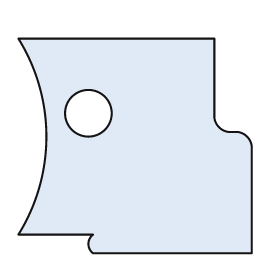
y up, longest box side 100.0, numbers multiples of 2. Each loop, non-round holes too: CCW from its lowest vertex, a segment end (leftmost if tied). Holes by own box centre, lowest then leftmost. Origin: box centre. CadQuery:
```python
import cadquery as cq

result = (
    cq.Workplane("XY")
    .moveTo(-18.0, -46.0)
    .lineTo(50.0, -46.0)
    .lineTo(50.0, 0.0)
    .threePointArc((48.0, 4.0), (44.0, 6.0))
    .lineTo(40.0, 6.0)
    .threePointArc((36.0, 8.0), (34.0, 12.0))
    .lineTo(34.0, 46.0)
    .lineTo(-50.0, 46.0)
    .threePointArc((-38.0, 4.0), (-50.0, -38.0))
    .lineTo(-18.0, -38.0)
    .threePointArc((-20.0, -42.0), (-18.0, -46.0))
    .close()
    .moveTo(-20.0, 14.0)
    .circle(10.0)
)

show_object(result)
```